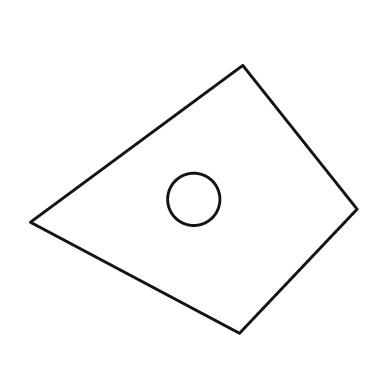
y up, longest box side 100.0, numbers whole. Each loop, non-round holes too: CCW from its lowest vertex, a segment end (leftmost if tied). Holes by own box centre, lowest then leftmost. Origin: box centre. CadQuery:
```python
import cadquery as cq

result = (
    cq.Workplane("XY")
    .moveTo(14.0, -41.0)
    .lineTo(50.0, -3.0)
    .lineTo(15.0, 41.0)
    .lineTo(-50.0, -7.0)
    .close()
    .moveTo(0.0, 0.0)
    .circle(8.0)
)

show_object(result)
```